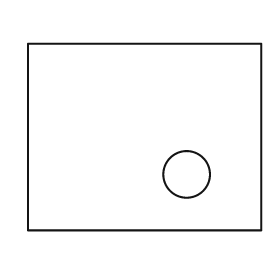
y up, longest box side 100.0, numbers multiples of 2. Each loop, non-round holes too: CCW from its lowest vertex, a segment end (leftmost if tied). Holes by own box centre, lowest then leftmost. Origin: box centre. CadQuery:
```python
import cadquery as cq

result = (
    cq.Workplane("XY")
    .moveTo(-50.0, -40.0)
    .lineTo(50.0, -40.0)
    .lineTo(50.0, 40.0)
    .lineTo(-50.0, 40.0)
    .close()
    .moveTo(18.0, -16.0)
    .circle(10.0)
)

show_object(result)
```